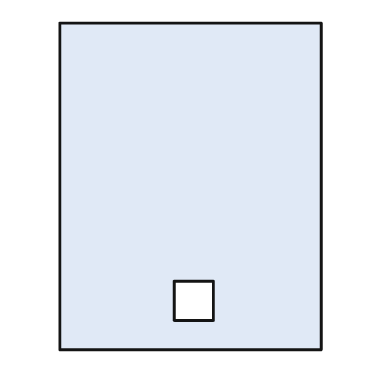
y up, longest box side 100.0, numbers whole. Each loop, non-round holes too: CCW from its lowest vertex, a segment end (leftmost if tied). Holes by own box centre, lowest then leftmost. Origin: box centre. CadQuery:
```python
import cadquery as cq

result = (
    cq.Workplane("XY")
    .moveTo(-40.0, -50.0)
    .lineTo(40.0, -50.0)
    .lineTo(40.0, 50.0)
    .lineTo(-40.0, 50.0)
    .close()
    .moveTo(-5.0, -41.0)
    .lineTo(7.0, -41.0)
    .lineTo(7.0, -29.0)
    .lineTo(-5.0, -29.0)
    .close()
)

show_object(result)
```